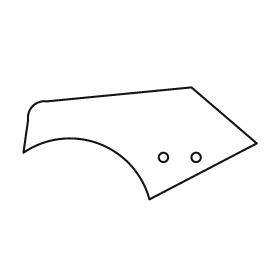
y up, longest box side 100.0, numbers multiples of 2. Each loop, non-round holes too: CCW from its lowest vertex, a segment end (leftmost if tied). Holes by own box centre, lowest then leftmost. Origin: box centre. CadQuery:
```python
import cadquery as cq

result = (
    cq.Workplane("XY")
    .moveTo(4.0, -24.0)
    .lineTo(50.0, 0.0)
    .lineTo(22.0, 24.0)
    .lineTo(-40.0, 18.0)
    .threePointArc((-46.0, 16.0), (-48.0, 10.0))
    .lineTo(-50.0, -4.0)
    .threePointArc((-18.0, 0.0), (4.0, -24.0))
    .close()
    .moveTo(10.0, -6.0)
    .circle(2.0)
    .moveTo(24.0, -6.0)
    .circle(2.0)
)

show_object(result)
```